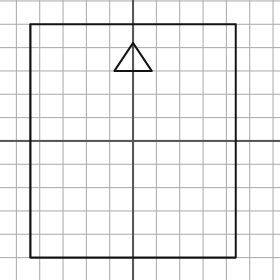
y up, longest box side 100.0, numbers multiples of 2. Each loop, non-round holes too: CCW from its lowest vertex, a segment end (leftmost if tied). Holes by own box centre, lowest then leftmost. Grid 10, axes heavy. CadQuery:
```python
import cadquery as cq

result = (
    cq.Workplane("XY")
    .moveTo(-44.0, -50.0)
    .lineTo(44.0, -50.0)
    .lineTo(44.0, 50.0)
    .lineTo(-44.0, 50.0)
    .close()
    .moveTo(-8.0, 30.0)
    .lineTo(8.0, 30.0)
    .lineTo(0.0, 42.0)
    .close()
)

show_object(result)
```